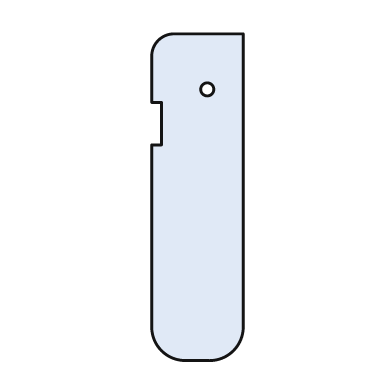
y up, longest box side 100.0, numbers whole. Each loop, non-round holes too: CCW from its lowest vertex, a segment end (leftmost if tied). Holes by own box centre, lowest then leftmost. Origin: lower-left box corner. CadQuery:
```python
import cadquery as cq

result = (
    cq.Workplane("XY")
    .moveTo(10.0, 0.0)
    .lineTo(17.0, 0.0)
    .threePointArc((25.0, 3.0), (28.0, 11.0))
    .lineTo(28.0, 100.0)
    .lineTo(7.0, 100.0)
    .threePointArc((2.0, 98.0), (0.0, 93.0))
    .lineTo(0.0, 79.0)
    .lineTo(3.0, 79.0)
    .lineTo(3.0, 66.0)
    .lineTo(0.0, 66.0)
    .lineTo(0.0, 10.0)
    .threePointArc((3.0, 3.0), (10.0, 0.0))
    .close()
    .moveTo(17.0, 83.0)
    .circle(2.0)
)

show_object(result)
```